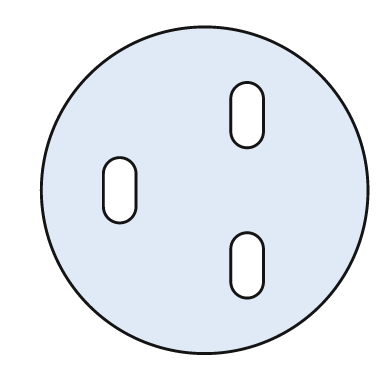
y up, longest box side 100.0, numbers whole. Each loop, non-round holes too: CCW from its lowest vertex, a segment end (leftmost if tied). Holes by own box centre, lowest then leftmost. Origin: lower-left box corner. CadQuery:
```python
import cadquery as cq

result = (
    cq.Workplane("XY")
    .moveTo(50.0, 50.0)
    .circle(50.0)
    .moveTo(58.0, 22.0)
    .threePointArc((63.0, 17.0), (68.0, 22.0))
    .lineTo(68.0, 32.0)
    .threePointArc((63.0, 37.0), (58.0, 32.0))
    .close()
    .moveTo(19.0, 45.0)
    .threePointArc((24.0, 40.0), (29.0, 45.0))
    .lineTo(29.0, 55.0)
    .threePointArc((24.0, 60.0), (19.0, 55.0))
    .close()
    .moveTo(58.0, 68.0)
    .threePointArc((63.0, 63.0), (68.0, 68.0))
    .lineTo(68.0, 78.0)
    .threePointArc((63.0, 83.0), (58.0, 78.0))
    .close()
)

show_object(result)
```